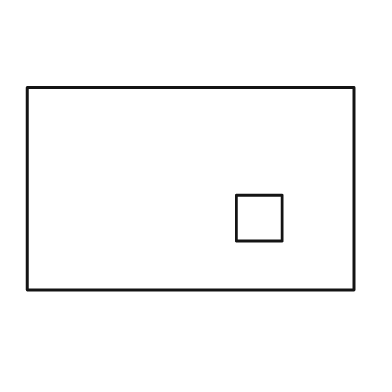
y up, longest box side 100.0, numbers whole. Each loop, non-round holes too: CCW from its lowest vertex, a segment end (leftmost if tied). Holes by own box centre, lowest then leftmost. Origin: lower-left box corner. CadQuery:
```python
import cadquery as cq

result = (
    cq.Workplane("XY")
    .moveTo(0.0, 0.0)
    .lineTo(100.0, 0.0)
    .lineTo(100.0, 62.0)
    .lineTo(0.0, 62.0)
    .close()
    .moveTo(64.0, 15.0)
    .lineTo(78.0, 15.0)
    .lineTo(78.0, 29.0)
    .lineTo(64.0, 29.0)
    .close()
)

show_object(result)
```